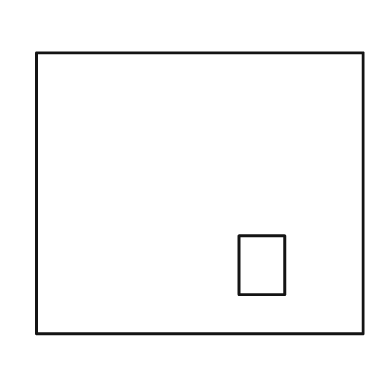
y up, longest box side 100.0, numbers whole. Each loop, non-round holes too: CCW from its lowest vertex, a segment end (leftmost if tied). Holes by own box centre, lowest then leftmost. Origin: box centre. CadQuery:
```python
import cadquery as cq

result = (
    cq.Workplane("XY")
    .moveTo(-50.0, -43.0)
    .lineTo(50.0, -43.0)
    .lineTo(50.0, 43.0)
    .lineTo(-50.0, 43.0)
    .close()
    .moveTo(12.0, -31.0)
    .lineTo(26.0, -31.0)
    .lineTo(26.0, -13.0)
    .lineTo(12.0, -13.0)
    .close()
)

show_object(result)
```